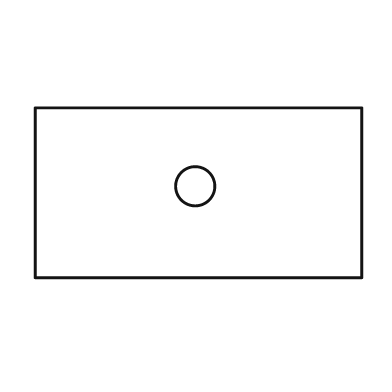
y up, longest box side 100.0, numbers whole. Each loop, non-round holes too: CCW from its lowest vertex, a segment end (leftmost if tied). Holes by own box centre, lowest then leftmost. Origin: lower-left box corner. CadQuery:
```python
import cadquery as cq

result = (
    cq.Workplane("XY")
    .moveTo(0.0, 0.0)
    .lineTo(100.0, 0.0)
    .lineTo(100.0, 52.0)
    .lineTo(0.0, 52.0)
    .close()
    .moveTo(49.0, 28.0)
    .circle(6.0)
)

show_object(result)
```